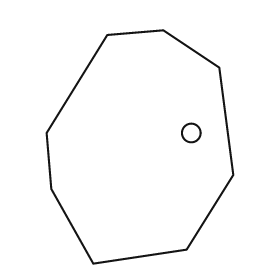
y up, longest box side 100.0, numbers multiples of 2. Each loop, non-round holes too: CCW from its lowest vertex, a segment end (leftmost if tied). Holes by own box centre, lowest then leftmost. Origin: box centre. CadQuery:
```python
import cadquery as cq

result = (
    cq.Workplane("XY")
    .moveTo(-20.0, -50.0)
    .lineTo(20.0, -44.0)
    .lineTo(40.0, -12.0)
    .lineTo(34.0, 34.0)
    .lineTo(10.0, 50.0)
    .lineTo(-14.0, 48.0)
    .lineTo(-40.0, 6.0)
    .lineTo(-38.0, -18.0)
    .close()
    .moveTo(22.0, 6.0)
    .circle(4.0)
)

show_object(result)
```